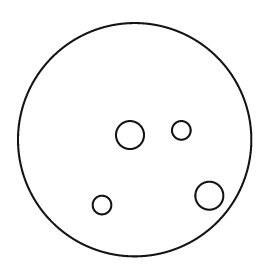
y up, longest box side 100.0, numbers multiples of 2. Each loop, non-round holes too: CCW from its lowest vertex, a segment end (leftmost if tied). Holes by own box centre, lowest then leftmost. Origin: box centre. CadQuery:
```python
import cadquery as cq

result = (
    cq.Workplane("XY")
    .moveTo(0.0, 0.0)
    .circle(50.0)
    .moveTo(-14.0, -28.0)
    .circle(4.0)
    .moveTo(32.0, -24.0)
    .circle(6.0)
    .moveTo(-2.0, 2.0)
    .circle(6.0)
    .moveTo(20.0, 4.0)
    .circle(4.0)
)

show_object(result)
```